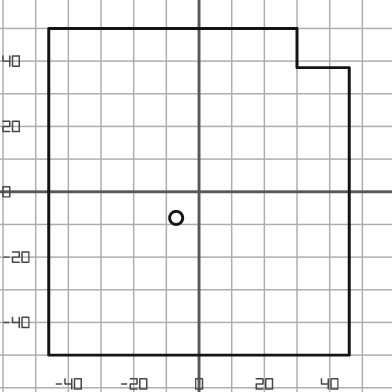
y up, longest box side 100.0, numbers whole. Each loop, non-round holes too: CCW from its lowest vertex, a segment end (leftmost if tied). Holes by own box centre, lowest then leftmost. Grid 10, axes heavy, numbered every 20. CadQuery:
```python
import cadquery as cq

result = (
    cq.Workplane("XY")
    .moveTo(-46.0, -50.0)
    .lineTo(46.0, -50.0)
    .lineTo(46.0, 38.0)
    .lineTo(30.0, 38.0)
    .lineTo(30.0, 50.0)
    .lineTo(-46.0, 50.0)
    .close()
    .moveTo(-7.0, -8.0)
    .circle(2.0)
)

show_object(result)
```